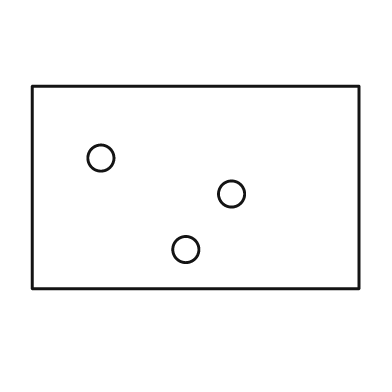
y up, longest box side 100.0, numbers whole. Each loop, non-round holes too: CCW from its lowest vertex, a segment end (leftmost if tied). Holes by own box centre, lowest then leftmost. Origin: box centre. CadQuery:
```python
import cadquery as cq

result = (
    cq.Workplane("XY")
    .moveTo(-50.0, -31.0)
    .lineTo(50.0, -31.0)
    .lineTo(50.0, 31.0)
    .lineTo(-50.0, 31.0)
    .close()
    .moveTo(-3.0, -19.0)
    .circle(4.0)
    .moveTo(11.0, -2.0)
    .circle(4.0)
    .moveTo(-29.0, 9.0)
    .circle(4.0)
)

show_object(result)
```